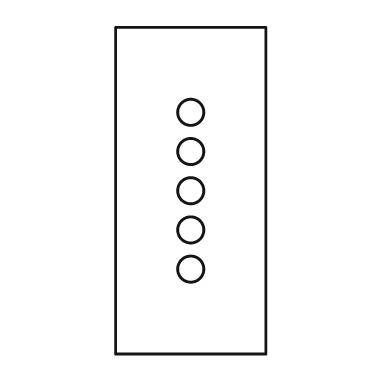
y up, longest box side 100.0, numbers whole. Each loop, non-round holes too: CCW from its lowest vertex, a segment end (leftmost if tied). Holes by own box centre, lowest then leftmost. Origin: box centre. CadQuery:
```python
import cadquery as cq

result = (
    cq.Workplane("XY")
    .moveTo(-23.0, -50.0)
    .lineTo(23.0, -50.0)
    .lineTo(23.0, 50.0)
    .lineTo(-23.0, 50.0)
    .close()
    .moveTo(0.0, -24.0)
    .circle(4.0)
    .moveTo(0.0, -12.0)
    .circle(4.0)
    .moveTo(0.0, 0.0)
    .circle(4.0)
    .moveTo(0.0, 12.0)
    .circle(4.0)
    .moveTo(0.0, 24.0)
    .circle(4.0)
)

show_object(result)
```